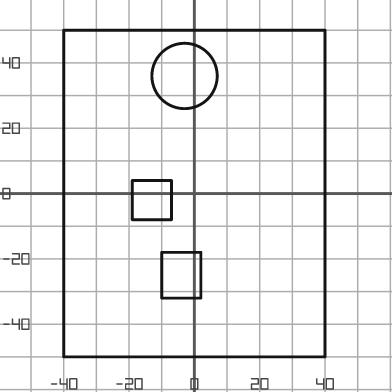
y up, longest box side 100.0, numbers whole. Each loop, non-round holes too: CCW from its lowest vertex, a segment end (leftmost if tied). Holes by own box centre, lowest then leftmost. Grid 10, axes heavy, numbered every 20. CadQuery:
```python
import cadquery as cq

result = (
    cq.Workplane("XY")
    .moveTo(-40.0, -50.0)
    .lineTo(40.0, -50.0)
    .lineTo(40.0, 50.0)
    .lineTo(-40.0, 50.0)
    .close()
    .moveTo(-10.0, -32.0)
    .lineTo(2.0, -32.0)
    .lineTo(2.0, -18.0)
    .lineTo(-10.0, -18.0)
    .close()
    .moveTo(-19.0, -8.0)
    .lineTo(-7.0, -8.0)
    .lineTo(-7.0, 4.0)
    .lineTo(-19.0, 4.0)
    .close()
    .moveTo(-3.0, 36.0)
    .circle(10.0)
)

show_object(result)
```